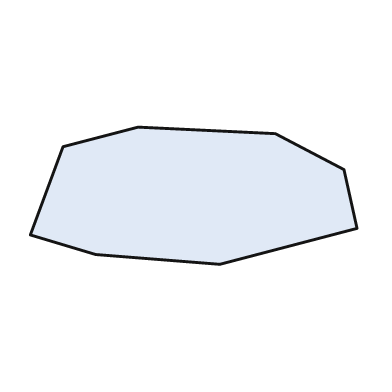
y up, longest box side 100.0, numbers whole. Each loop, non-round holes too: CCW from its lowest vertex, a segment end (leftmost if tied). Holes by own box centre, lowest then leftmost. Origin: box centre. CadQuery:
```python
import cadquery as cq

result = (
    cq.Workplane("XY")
    .moveTo(8.0, -21.0)
    .lineTo(50.0, -10.0)
    .lineTo(46.0, 8.0)
    .lineTo(25.0, 19.0)
    .lineTo(-17.0, 21.0)
    .lineTo(-40.0, 15.0)
    .lineTo(-50.0, -12.0)
    .lineTo(-30.0, -18.0)
    .close()
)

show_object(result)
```